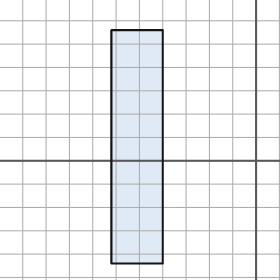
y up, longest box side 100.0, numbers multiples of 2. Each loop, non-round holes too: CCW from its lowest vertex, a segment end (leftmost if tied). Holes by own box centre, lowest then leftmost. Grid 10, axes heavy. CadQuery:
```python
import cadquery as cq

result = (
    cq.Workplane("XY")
    .moveTo(-62.0, -44.0)
    .lineTo(-40.0, -44.0)
    .lineTo(-40.0, 56.0)
    .lineTo(-62.0, 56.0)
    .close()
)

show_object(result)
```